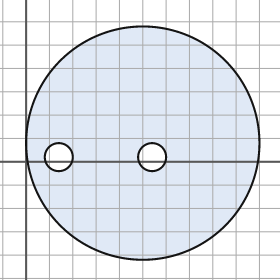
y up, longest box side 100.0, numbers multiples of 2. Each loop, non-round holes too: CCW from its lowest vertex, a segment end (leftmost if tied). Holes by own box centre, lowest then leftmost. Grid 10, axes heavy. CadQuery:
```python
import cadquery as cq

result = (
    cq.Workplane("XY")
    .moveTo(50.0, 8.0)
    .circle(50.0)
    .moveTo(14.0, 2.0)
    .circle(6.0)
    .moveTo(54.0, 2.0)
    .circle(6.0)
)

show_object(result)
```